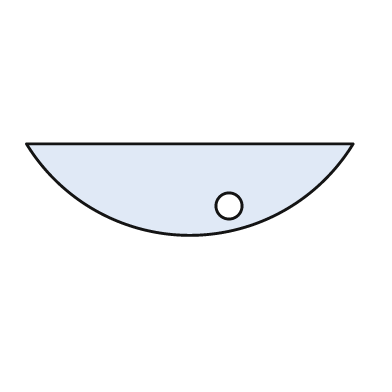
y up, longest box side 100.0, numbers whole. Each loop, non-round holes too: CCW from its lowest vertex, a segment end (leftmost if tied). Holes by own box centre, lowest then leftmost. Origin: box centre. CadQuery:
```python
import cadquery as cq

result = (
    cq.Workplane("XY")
    .moveTo(-50.0, 14.0)
    .threePointArc((0.0, -14.0), (50.0, 14.0))
    .close()
    .moveTo(12.0, -5.0)
    .circle(4.0)
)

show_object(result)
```